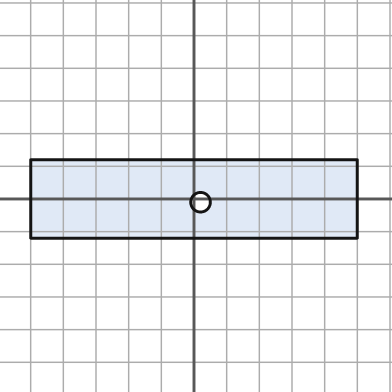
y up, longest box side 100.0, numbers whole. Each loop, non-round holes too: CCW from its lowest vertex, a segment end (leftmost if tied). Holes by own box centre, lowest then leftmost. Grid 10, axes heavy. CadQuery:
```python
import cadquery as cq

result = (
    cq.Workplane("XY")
    .moveTo(-50.0, -12.0)
    .lineTo(50.0, -12.0)
    .lineTo(50.0, 12.0)
    .lineTo(-50.0, 12.0)
    .close()
    .moveTo(2.0, -1.0)
    .circle(3.0)
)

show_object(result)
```